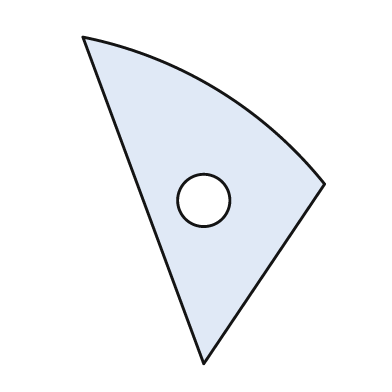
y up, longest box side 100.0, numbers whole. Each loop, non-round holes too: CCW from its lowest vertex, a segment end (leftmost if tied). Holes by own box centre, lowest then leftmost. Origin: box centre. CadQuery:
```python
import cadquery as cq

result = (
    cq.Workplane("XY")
    .moveTo(0.0, -50.0)
    .lineTo(37.0, 5.0)
    .threePointArc((4.0, 34.0), (-37.0, 50.0))
    .close()
    .moveTo(0.0, 0.0)
    .circle(8.0)
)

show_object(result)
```